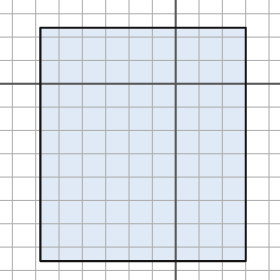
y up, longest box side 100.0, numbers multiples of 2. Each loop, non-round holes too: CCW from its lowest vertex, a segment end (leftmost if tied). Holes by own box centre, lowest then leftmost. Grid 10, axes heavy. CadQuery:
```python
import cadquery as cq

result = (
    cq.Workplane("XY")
    .moveTo(-58.0, -76.0)
    .lineTo(30.0, -76.0)
    .lineTo(30.0, 24.0)
    .lineTo(-58.0, 24.0)
    .close()
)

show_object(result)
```